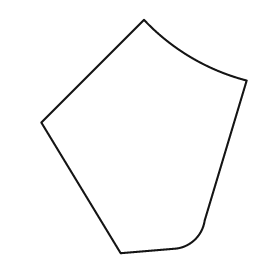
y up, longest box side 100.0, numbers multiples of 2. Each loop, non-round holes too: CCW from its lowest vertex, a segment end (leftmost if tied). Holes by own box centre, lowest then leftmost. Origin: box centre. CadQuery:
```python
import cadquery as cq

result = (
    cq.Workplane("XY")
    .moveTo(-10.0, -50.0)
    .lineTo(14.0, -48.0)
    .threePointArc((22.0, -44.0), (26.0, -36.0))
    .lineTo(44.0, 24.0)
    .threePointArc((20.0, 34.0), (0.0, 50.0))
    .lineTo(-44.0, 6.0)
    .close()
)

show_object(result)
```